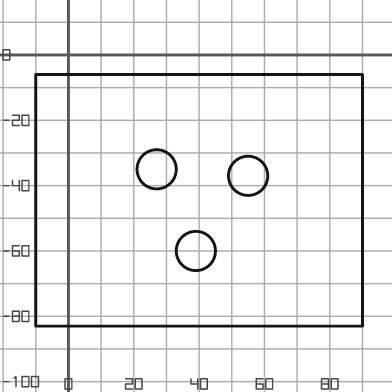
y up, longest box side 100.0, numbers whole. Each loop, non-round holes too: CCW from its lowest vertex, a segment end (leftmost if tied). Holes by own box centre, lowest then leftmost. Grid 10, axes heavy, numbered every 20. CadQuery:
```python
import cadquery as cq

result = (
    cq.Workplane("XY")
    .moveTo(-10.0, -83.0)
    .lineTo(90.0, -83.0)
    .lineTo(90.0, -6.0)
    .lineTo(-10.0, -6.0)
    .close()
    .moveTo(39.0, -60.0)
    .circle(6.0)
    .moveTo(55.0, -37.0)
    .circle(6.0)
    .moveTo(27.0, -35.0)
    .circle(6.0)
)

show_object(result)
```